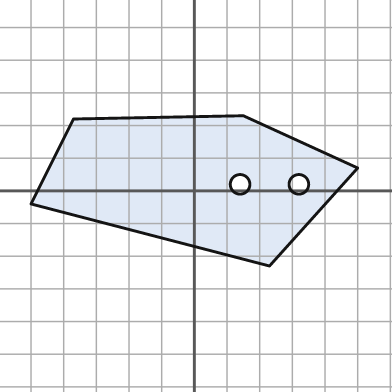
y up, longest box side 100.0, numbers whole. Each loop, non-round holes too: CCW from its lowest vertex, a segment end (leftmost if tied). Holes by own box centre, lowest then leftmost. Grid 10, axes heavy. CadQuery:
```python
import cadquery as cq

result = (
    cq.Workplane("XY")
    .moveTo(23.0, -23.0)
    .lineTo(50.0, 7.0)
    .lineTo(15.0, 23.0)
    .lineTo(-37.0, 22.0)
    .lineTo(-50.0, -4.0)
    .close()
    .moveTo(14.0, 2.0)
    .circle(3.0)
    .moveTo(32.0, 2.0)
    .circle(3.0)
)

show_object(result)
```